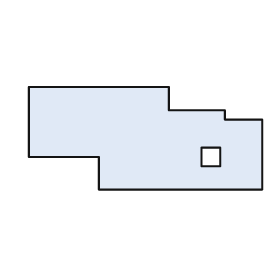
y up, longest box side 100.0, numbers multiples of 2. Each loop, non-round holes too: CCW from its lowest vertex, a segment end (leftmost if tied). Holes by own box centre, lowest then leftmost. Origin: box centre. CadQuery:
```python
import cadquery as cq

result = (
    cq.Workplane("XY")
    .moveTo(-20.0, -22.0)
    .lineTo(50.0, -22.0)
    .lineTo(50.0, 8.0)
    .lineTo(34.0, 8.0)
    .lineTo(34.0, 12.0)
    .lineTo(10.0, 12.0)
    .lineTo(10.0, 22.0)
    .lineTo(-50.0, 22.0)
    .lineTo(-50.0, -8.0)
    .lineTo(-20.0, -8.0)
    .close()
    .moveTo(24.0, -12.0)
    .lineTo(32.0, -12.0)
    .lineTo(32.0, -4.0)
    .lineTo(24.0, -4.0)
    .close()
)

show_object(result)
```